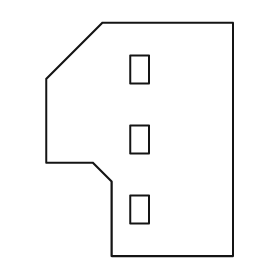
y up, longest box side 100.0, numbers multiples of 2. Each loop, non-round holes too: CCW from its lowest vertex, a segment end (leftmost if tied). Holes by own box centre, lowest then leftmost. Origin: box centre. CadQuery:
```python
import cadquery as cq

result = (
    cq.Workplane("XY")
    .moveTo(-12.0, -50.0)
    .lineTo(40.0, -50.0)
    .lineTo(40.0, 50.0)
    .lineTo(-16.0, 50.0)
    .lineTo(-40.0, 26.0)
    .lineTo(-40.0, -10.0)
    .lineTo(-20.0, -10.0)
    .lineTo(-12.0, -18.0)
    .close()
    .moveTo(-4.0, -36.0)
    .lineTo(4.0, -36.0)
    .lineTo(4.0, -24.0)
    .lineTo(-4.0, -24.0)
    .close()
    .moveTo(-4.0, -6.0)
    .lineTo(4.0, -6.0)
    .lineTo(4.0, 6.0)
    .lineTo(-4.0, 6.0)
    .close()
    .moveTo(-4.0, 24.0)
    .lineTo(4.0, 24.0)
    .lineTo(4.0, 36.0)
    .lineTo(-4.0, 36.0)
    .close()
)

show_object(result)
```